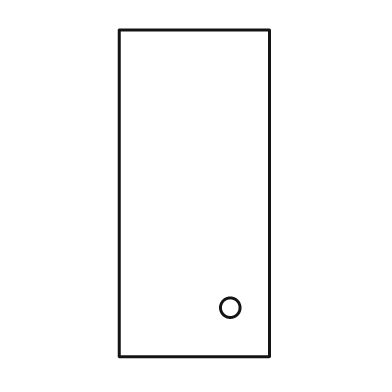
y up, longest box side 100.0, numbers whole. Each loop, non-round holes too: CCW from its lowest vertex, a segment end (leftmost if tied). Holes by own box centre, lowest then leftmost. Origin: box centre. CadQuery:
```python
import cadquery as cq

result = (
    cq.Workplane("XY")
    .moveTo(-23.0, -50.0)
    .lineTo(23.0, -50.0)
    .lineTo(23.0, 50.0)
    .lineTo(-23.0, 50.0)
    .close()
    .moveTo(11.0, -35.0)
    .circle(3.0)
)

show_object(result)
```